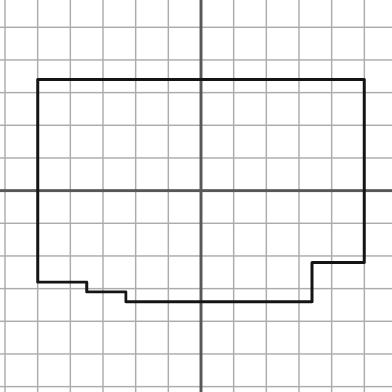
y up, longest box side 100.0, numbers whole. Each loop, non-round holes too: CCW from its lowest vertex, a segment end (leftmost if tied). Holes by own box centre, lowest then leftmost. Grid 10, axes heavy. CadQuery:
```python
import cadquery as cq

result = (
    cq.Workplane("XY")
    .moveTo(-23.0, -34.0)
    .lineTo(34.0, -34.0)
    .lineTo(34.0, -22.0)
    .lineTo(50.0, -22.0)
    .lineTo(50.0, 34.0)
    .lineTo(-50.0, 34.0)
    .lineTo(-50.0, -28.0)
    .lineTo(-35.0, -28.0)
    .lineTo(-35.0, -31.0)
    .lineTo(-23.0, -31.0)
    .close()
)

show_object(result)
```